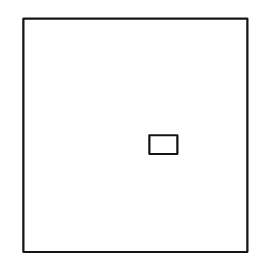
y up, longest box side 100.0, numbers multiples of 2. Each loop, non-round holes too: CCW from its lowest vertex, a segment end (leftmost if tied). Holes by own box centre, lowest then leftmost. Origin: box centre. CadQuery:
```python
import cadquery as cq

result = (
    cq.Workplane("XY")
    .moveTo(-48.0, -50.0)
    .lineTo(48.0, -50.0)
    .lineTo(48.0, 50.0)
    .lineTo(-48.0, 50.0)
    .close()
    .moveTo(6.0, -8.0)
    .lineTo(18.0, -8.0)
    .lineTo(18.0, 0.0)
    .lineTo(6.0, 0.0)
    .close()
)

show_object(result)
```